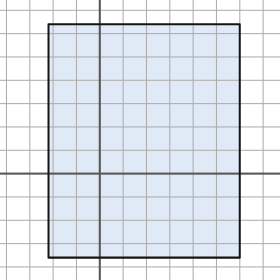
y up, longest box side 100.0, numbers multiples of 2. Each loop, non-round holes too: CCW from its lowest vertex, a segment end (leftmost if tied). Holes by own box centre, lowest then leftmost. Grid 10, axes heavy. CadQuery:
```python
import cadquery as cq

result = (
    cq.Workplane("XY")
    .moveTo(-22.0, -36.0)
    .lineTo(60.0, -36.0)
    .lineTo(60.0, 64.0)
    .lineTo(-22.0, 64.0)
    .close()
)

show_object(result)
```